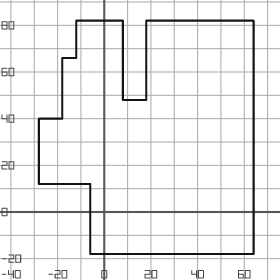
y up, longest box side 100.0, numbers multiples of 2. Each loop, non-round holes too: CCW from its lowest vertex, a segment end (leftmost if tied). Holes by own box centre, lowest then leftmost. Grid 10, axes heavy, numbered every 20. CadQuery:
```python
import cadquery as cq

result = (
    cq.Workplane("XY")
    .moveTo(-6.0, -18.0)
    .lineTo(64.0, -18.0)
    .lineTo(64.0, 82.0)
    .lineTo(18.0, 82.0)
    .lineTo(18.0, 48.0)
    .lineTo(8.0, 48.0)
    .lineTo(8.0, 82.0)
    .lineTo(-12.0, 82.0)
    .lineTo(-12.0, 66.0)
    .lineTo(-18.0, 66.0)
    .lineTo(-18.0, 40.0)
    .lineTo(-28.0, 40.0)
    .lineTo(-28.0, 12.0)
    .lineTo(-6.0, 12.0)
    .close()
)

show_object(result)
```